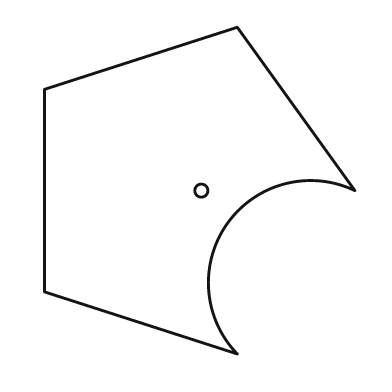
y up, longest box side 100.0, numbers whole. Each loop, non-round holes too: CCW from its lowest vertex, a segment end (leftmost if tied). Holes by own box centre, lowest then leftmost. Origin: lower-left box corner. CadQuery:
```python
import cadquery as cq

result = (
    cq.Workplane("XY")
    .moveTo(59.0, 0.0)
    .threePointArc((56.0, 40.0), (95.0, 50.0))
    .lineTo(59.0, 100.0)
    .lineTo(0.0, 81.0)
    .lineTo(0.0, 19.0)
    .close()
    .moveTo(48.0, 50.0)
    .circle(2.0)
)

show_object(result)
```